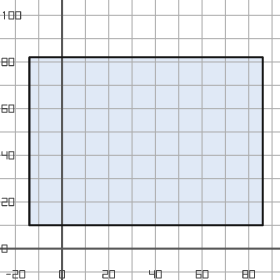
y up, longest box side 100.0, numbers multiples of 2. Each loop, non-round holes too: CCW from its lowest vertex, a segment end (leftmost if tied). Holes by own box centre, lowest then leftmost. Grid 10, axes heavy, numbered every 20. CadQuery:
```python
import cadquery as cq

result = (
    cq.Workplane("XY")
    .moveTo(-14.0, 10.0)
    .lineTo(86.0, 10.0)
    .lineTo(86.0, 82.0)
    .lineTo(-14.0, 82.0)
    .close()
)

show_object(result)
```